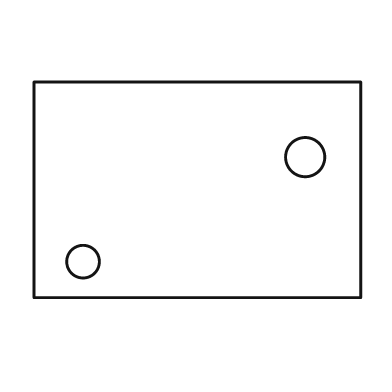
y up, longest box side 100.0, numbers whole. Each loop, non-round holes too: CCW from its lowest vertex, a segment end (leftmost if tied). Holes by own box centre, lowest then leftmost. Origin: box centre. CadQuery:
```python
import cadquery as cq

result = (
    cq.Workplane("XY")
    .moveTo(-50.0, -33.0)
    .lineTo(50.0, -33.0)
    .lineTo(50.0, 33.0)
    .lineTo(-50.0, 33.0)
    .close()
    .moveTo(-35.0, -22.0)
    .circle(5.0)
    .moveTo(33.0, 10.0)
    .circle(6.0)
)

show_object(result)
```